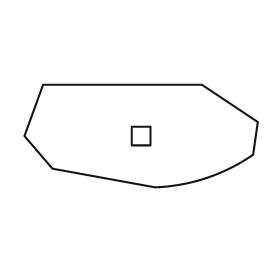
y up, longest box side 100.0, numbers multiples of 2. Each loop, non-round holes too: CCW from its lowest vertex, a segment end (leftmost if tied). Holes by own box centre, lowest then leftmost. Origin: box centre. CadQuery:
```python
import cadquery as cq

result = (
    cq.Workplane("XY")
    .moveTo(6.0, -22.0)
    .threePointArc((28.0, -18.0), (48.0, -8.0))
    .lineTo(50.0, 6.0)
    .lineTo(26.0, 22.0)
    .lineTo(-42.0, 22.0)
    .lineTo(-50.0, 0.0)
    .lineTo(-38.0, -14.0)
    .close()
    .moveTo(-4.0, -4.0)
    .lineTo(4.0, -4.0)
    .lineTo(4.0, 4.0)
    .lineTo(-4.0, 4.0)
    .close()
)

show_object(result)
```